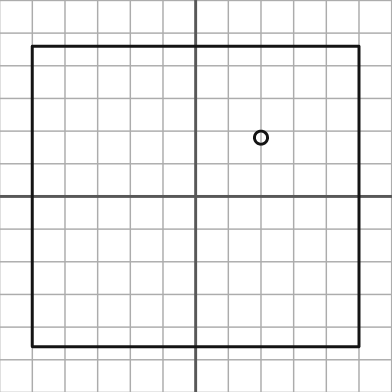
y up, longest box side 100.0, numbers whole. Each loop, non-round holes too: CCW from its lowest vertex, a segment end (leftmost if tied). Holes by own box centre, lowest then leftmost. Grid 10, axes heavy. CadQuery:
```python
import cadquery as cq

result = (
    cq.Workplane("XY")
    .moveTo(-50.0, -46.0)
    .lineTo(50.0, -46.0)
    .lineTo(50.0, 46.0)
    .lineTo(-50.0, 46.0)
    .close()
    .moveTo(20.0, 18.0)
    .circle(2.0)
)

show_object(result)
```